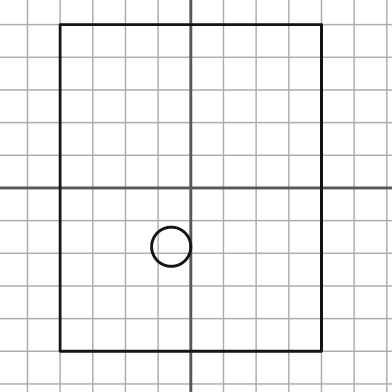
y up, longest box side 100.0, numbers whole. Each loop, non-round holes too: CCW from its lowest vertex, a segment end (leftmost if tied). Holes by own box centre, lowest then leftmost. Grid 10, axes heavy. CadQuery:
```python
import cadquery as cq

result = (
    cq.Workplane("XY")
    .moveTo(-40.0, -50.0)
    .lineTo(40.0, -50.0)
    .lineTo(40.0, 50.0)
    .lineTo(-40.0, 50.0)
    .close()
    .moveTo(-6.0, -18.0)
    .circle(6.0)
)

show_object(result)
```